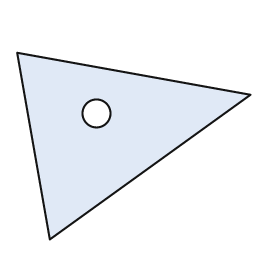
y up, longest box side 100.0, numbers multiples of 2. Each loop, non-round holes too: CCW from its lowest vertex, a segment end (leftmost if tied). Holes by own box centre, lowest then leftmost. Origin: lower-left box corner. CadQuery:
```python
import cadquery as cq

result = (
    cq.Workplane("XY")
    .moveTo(14.0, 0.0)
    .lineTo(100.0, 62.0)
    .lineTo(0.0, 80.0)
    .close()
    .moveTo(34.0, 54.0)
    .circle(6.0)
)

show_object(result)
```